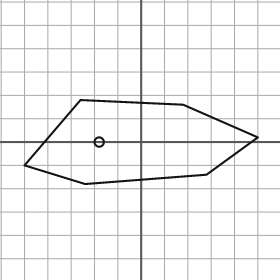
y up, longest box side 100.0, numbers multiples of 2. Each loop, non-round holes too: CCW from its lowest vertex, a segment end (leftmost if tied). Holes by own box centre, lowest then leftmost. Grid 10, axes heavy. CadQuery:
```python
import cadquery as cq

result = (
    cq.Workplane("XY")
    .moveTo(-24.0, -18.0)
    .lineTo(28.0, -14.0)
    .lineTo(50.0, 2.0)
    .lineTo(18.0, 16.0)
    .lineTo(-26.0, 18.0)
    .lineTo(-50.0, -10.0)
    .close()
    .moveTo(-18.0, 0.0)
    .circle(2.0)
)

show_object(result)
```